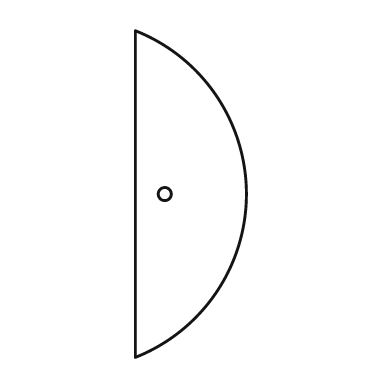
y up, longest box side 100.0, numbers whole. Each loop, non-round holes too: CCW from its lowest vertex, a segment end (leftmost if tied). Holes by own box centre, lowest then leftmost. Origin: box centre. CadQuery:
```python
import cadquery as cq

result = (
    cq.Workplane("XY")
    .moveTo(-17.0, -50.0)
    .threePointArc((17.0, 0.0), (-17.0, 50.0))
    .close()
    .moveTo(-8.0, 0.0)
    .circle(2.0)
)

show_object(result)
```